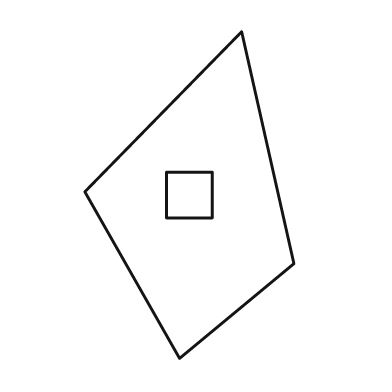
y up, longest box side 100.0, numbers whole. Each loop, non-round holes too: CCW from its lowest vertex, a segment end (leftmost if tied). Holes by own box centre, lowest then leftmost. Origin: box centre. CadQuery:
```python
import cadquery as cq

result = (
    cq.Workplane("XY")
    .moveTo(-3.0, -50.0)
    .lineTo(32.0, -21.0)
    .lineTo(16.0, 50.0)
    .lineTo(-32.0, 1.0)
    .close()
    .moveTo(-7.0, -7.0)
    .lineTo(7.0, -7.0)
    .lineTo(7.0, 7.0)
    .lineTo(-7.0, 7.0)
    .close()
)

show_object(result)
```